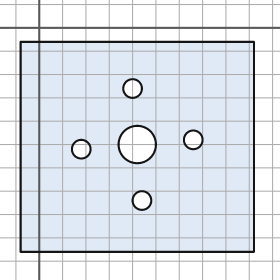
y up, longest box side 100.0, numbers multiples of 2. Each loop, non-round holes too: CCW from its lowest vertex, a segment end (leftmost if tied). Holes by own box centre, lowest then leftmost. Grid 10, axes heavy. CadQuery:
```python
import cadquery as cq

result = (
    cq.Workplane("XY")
    .moveTo(-8.0, -96.0)
    .lineTo(92.0, -96.0)
    .lineTo(92.0, -6.0)
    .lineTo(-8.0, -6.0)
    .close()
    .moveTo(44.0, -74.0)
    .circle(4.0)
    .moveTo(18.0, -52.0)
    .circle(4.0)
    .moveTo(42.0, -50.0)
    .circle(8.0)
    .moveTo(66.0, -48.0)
    .circle(4.0)
    .moveTo(40.0, -26.0)
    .circle(4.0)
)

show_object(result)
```